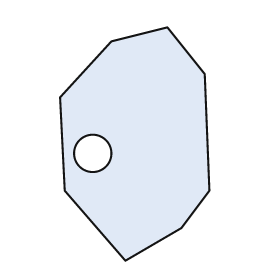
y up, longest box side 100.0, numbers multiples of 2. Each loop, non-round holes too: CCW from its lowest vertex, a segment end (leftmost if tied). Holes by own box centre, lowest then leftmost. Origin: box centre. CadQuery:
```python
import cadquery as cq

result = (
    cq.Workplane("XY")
    .moveTo(-4.0, -50.0)
    .lineTo(20.0, -36.0)
    .lineTo(32.0, -20.0)
    .lineTo(30.0, 30.0)
    .lineTo(14.0, 50.0)
    .lineTo(-10.0, 44.0)
    .lineTo(-32.0, 20.0)
    .lineTo(-30.0, -20.0)
    .close()
    .moveTo(-18.0, -4.0)
    .circle(8.0)
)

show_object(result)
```